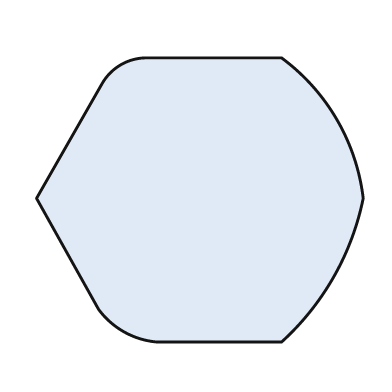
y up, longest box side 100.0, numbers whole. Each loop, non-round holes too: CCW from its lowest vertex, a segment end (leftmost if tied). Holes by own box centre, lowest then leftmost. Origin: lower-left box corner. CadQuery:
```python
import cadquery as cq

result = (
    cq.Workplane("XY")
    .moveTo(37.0, 0.0)
    .lineTo(75.0, 0.0)
    .threePointArc((91.0, 20.0), (100.0, 44.0))
    .threePointArc((92.0, 68.0), (75.0, 87.0))
    .lineTo(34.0, 87.0)
    .threePointArc((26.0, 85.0), (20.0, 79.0))
    .lineTo(0.0, 44.0)
    .lineTo(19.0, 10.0)
    .threePointArc((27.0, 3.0), (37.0, 0.0))
    .close()
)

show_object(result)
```